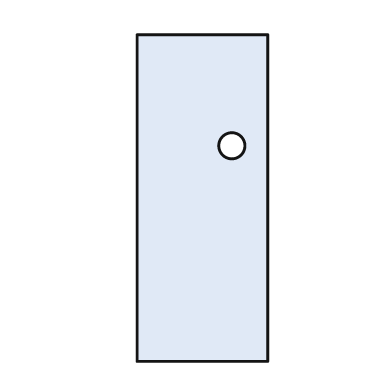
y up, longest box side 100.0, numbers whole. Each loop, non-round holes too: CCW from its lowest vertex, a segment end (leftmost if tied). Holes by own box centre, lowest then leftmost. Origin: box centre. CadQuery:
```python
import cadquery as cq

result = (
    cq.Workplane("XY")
    .moveTo(-20.0, -50.0)
    .lineTo(20.0, -50.0)
    .lineTo(20.0, 50.0)
    .lineTo(-20.0, 50.0)
    .close()
    .moveTo(9.0, 16.0)
    .circle(4.0)
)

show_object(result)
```